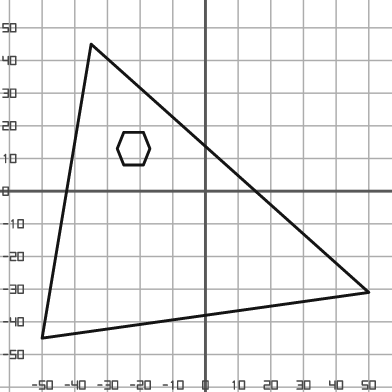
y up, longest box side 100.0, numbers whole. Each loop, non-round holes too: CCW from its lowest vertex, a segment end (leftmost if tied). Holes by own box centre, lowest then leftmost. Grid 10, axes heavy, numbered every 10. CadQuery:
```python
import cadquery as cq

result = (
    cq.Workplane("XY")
    .moveTo(-50.0, -45.0)
    .lineTo(50.0, -31.0)
    .lineTo(-35.0, 45.0)
    .close()
    .moveTo(-25.0, 8.0)
    .lineTo(-19.0, 8.0)
    .lineTo(-17.0, 13.0)
    .lineTo(-19.0, 18.0)
    .lineTo(-25.0, 18.0)
    .lineTo(-27.0, 13.0)
    .close()
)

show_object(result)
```